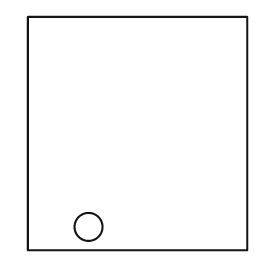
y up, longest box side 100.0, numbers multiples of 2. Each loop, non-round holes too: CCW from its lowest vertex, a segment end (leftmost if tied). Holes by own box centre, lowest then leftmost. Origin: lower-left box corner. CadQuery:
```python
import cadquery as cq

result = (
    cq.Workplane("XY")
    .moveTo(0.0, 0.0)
    .lineTo(94.0, 0.0)
    .lineTo(94.0, 100.0)
    .lineTo(0.0, 100.0)
    .close()
    .moveTo(26.0, 10.0)
    .circle(6.0)
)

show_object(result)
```